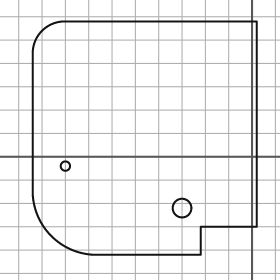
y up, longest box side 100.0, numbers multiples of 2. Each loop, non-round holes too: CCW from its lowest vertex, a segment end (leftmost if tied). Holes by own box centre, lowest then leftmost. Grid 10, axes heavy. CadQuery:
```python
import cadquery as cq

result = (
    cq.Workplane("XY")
    .moveTo(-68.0, -42.0)
    .lineTo(-22.0, -42.0)
    .lineTo(-22.0, -30.0)
    .lineTo(2.0, -30.0)
    .lineTo(2.0, 58.0)
    .lineTo(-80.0, 58.0)
    .threePointArc((-90.0, 54.0), (-94.0, 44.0))
    .lineTo(-94.0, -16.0)
    .threePointArc((-86.0, -34.0), (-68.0, -42.0))
    .close()
    .moveTo(-30.0, -22.0)
    .circle(4.0)
    .moveTo(-80.0, -4.0)
    .circle(2.0)
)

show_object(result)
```